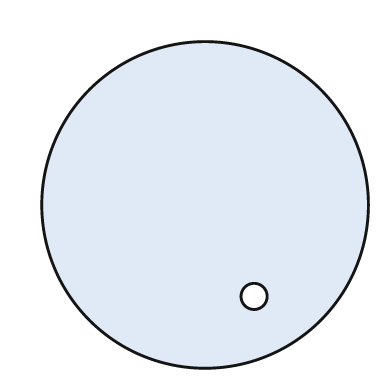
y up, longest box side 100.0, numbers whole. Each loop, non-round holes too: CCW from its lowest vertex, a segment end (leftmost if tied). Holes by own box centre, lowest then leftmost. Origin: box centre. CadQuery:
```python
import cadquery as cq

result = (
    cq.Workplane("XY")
    .moveTo(0.0, 0.0)
    .circle(50.0)
    .moveTo(15.0, -28.0)
    .circle(4.0)
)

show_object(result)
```